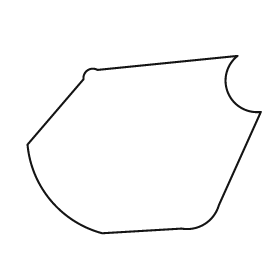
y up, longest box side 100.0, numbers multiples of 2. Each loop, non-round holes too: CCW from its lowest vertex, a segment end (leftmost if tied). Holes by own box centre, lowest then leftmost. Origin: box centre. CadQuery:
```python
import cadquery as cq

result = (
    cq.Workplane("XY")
    .moveTo(-18.0, -38.0)
    .lineTo(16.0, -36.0)
    .threePointArc((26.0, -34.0), (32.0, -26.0))
    .lineTo(50.0, 14.0)
    .threePointArc((36.0, 22.0), (40.0, 38.0))
    .lineTo(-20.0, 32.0)
    .threePointArc((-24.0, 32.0), (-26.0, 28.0))
    .lineTo(-50.0, 0.0)
    .threePointArc((-40.0, -24.0), (-18.0, -38.0))
    .close()
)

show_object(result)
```